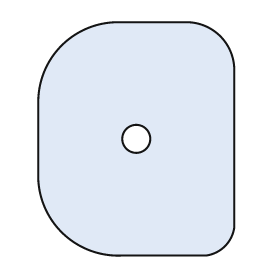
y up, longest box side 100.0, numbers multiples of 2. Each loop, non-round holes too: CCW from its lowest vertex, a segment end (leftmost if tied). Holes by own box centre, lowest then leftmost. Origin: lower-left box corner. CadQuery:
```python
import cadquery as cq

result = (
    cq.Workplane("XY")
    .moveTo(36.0, 0.0)
    .lineTo(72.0, 0.0)
    .threePointArc((80.0, 4.0), (84.0, 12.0))
    .lineTo(84.0, 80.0)
    .threePointArc((78.0, 94.0), (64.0, 100.0))
    .lineTo(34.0, 100.0)
    .threePointArc((10.0, 90.0), (0.0, 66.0))
    .lineTo(0.0, 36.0)
    .threePointArc((10.0, 10.0), (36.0, 0.0))
    .close()
    .moveTo(42.0, 50.0)
    .circle(6.0)
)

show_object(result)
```